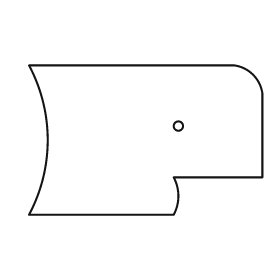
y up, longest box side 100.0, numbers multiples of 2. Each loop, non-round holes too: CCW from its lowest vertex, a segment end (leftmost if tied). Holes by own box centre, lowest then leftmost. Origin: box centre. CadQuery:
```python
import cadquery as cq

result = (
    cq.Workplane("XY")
    .moveTo(-50.0, -32.0)
    .lineTo(12.0, -32.0)
    .threePointArc((14.0, -24.0), (12.0, -16.0))
    .lineTo(50.0, -16.0)
    .lineTo(50.0, 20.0)
    .threePointArc((46.0, 28.0), (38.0, 32.0))
    .lineTo(-50.0, 32.0)
    .threePointArc((-42.0, 0.0), (-50.0, -32.0))
    .close()
    .moveTo(14.0, 6.0)
    .circle(2.0)
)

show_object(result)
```